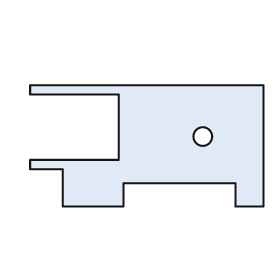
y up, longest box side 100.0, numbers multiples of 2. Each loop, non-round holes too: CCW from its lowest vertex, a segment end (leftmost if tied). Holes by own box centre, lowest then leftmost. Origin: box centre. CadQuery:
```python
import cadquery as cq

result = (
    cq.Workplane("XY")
    .moveTo(-36.0, -26.0)
    .lineTo(-10.0, -26.0)
    .lineTo(-10.0, -16.0)
    .lineTo(38.0, -16.0)
    .lineTo(38.0, -26.0)
    .lineTo(50.0, -26.0)
    .lineTo(50.0, 26.0)
    .lineTo(-50.0, 26.0)
    .lineTo(-50.0, 22.0)
    .lineTo(-12.0, 22.0)
    .lineTo(-12.0, -6.0)
    .lineTo(-50.0, -6.0)
    .lineTo(-50.0, -10.0)
    .lineTo(-36.0, -10.0)
    .close()
    .moveTo(24.0, 4.0)
    .circle(4.0)
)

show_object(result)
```